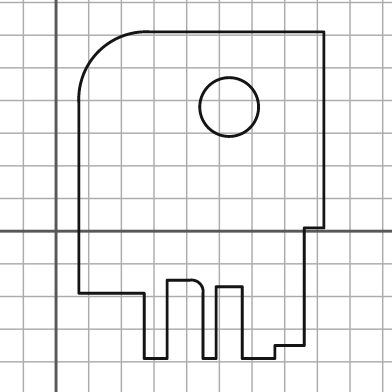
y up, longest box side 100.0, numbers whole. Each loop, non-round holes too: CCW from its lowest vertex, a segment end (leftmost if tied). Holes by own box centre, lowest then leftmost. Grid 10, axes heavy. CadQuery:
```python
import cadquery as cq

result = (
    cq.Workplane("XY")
    .moveTo(27.0, -39.0)
    .lineTo(34.0, -39.0)
    .lineTo(34.0, -15.0)
    .lineTo(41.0, -15.0)
    .threePointArc((44.0, -16.0), (45.0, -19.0))
    .lineTo(45.0, -39.0)
    .lineTo(49.0, -39.0)
    .lineTo(49.0, -17.0)
    .lineTo(57.0, -17.0)
    .lineTo(57.0, -39.0)
    .lineTo(67.0, -39.0)
    .lineTo(67.0, -35.0)
    .lineTo(76.0, -35.0)
    .lineTo(76.0, 1.0)
    .lineTo(82.0, 1.0)
    .lineTo(82.0, 61.0)
    .lineTo(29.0, 61.0)
    .threePointArc((13.0, 55.0), (7.0, 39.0))
    .lineTo(7.0, -19.0)
    .lineTo(27.0, -19.0)
    .close()
    .moveTo(53.0, 38.0)
    .circle(9.0)
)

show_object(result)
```